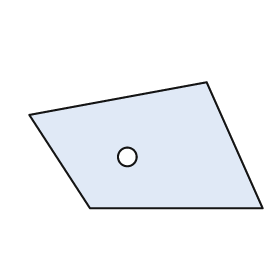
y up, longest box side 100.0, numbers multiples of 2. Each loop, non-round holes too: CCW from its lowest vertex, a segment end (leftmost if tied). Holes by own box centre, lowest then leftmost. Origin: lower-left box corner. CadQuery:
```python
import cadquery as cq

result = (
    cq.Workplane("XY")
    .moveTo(26.0, 0.0)
    .lineTo(100.0, 0.0)
    .lineTo(76.0, 54.0)
    .lineTo(0.0, 40.0)
    .close()
    .moveTo(42.0, 22.0)
    .circle(4.0)
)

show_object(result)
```